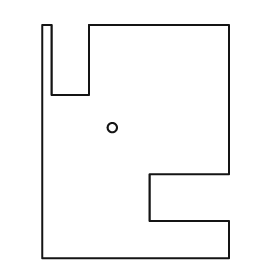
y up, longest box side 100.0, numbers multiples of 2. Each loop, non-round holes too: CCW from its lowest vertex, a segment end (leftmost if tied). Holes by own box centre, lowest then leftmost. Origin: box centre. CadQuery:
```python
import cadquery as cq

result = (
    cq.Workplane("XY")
    .moveTo(-40.0, -50.0)
    .lineTo(40.0, -50.0)
    .lineTo(40.0, -34.0)
    .lineTo(6.0, -34.0)
    .lineTo(6.0, -14.0)
    .lineTo(40.0, -14.0)
    .lineTo(40.0, 50.0)
    .lineTo(-20.0, 50.0)
    .lineTo(-20.0, 20.0)
    .lineTo(-36.0, 20.0)
    .lineTo(-36.0, 50.0)
    .lineTo(-40.0, 50.0)
    .close()
    .moveTo(-10.0, 6.0)
    .circle(2.0)
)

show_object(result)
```